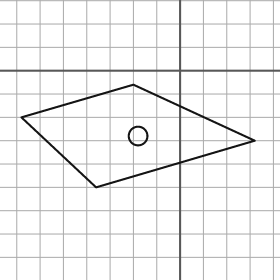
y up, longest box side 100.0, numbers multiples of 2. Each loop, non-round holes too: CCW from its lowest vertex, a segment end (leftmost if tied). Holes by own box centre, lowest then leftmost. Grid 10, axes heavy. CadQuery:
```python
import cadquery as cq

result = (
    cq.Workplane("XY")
    .moveTo(-36.0, -50.0)
    .lineTo(32.0, -30.0)
    .lineTo(-20.0, -6.0)
    .lineTo(-68.0, -20.0)
    .close()
    .moveTo(-18.0, -28.0)
    .circle(4.0)
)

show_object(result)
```